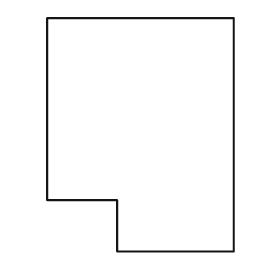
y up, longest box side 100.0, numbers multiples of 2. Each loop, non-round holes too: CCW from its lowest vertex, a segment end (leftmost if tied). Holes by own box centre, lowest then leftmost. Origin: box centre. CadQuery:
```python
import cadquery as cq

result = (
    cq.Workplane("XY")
    .moveTo(-10.0, -50.0)
    .lineTo(40.0, -50.0)
    .lineTo(40.0, 50.0)
    .lineTo(-40.0, 50.0)
    .lineTo(-40.0, -28.0)
    .lineTo(-10.0, -28.0)
    .close()
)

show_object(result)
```